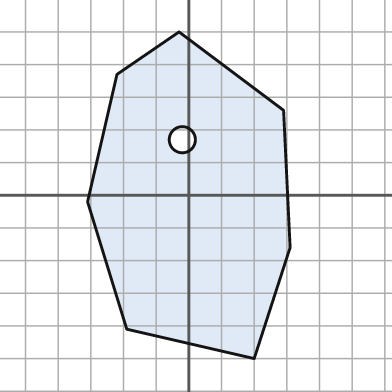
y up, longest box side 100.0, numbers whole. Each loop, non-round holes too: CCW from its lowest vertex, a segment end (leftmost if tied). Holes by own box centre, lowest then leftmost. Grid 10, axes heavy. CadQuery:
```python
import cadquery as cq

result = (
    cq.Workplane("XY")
    .moveTo(20.0, -50.0)
    .lineTo(31.0, -16.0)
    .lineTo(29.0, 26.0)
    .lineTo(-3.0, 50.0)
    .lineTo(-22.0, 37.0)
    .lineTo(-31.0, -2.0)
    .lineTo(-19.0, -41.0)
    .close()
    .moveTo(-2.0, 17.0)
    .circle(4.0)
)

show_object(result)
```